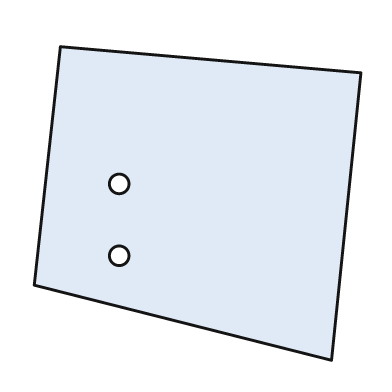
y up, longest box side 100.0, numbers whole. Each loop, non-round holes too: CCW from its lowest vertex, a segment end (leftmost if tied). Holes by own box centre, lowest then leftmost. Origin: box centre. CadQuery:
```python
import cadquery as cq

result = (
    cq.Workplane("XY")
    .moveTo(41.0, -48.0)
    .lineTo(50.0, 40.0)
    .lineTo(-42.0, 48.0)
    .lineTo(-50.0, -25.0)
    .close()
    .moveTo(-24.0, -16.0)
    .circle(3.0)
    .moveTo(-24.0, 6.0)
    .circle(3.0)
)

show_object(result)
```